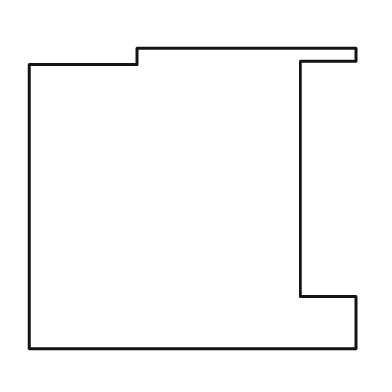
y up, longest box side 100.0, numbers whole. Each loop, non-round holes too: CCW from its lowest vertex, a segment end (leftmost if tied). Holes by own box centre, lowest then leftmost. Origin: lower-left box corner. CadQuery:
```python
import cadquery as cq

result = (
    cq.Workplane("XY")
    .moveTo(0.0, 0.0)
    .lineTo(100.0, 0.0)
    .lineTo(100.0, 16.0)
    .lineTo(83.0, 16.0)
    .lineTo(83.0, 88.0)
    .lineTo(100.0, 88.0)
    .lineTo(100.0, 92.0)
    .lineTo(33.0, 92.0)
    .lineTo(33.0, 87.0)
    .lineTo(0.0, 87.0)
    .close()
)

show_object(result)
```